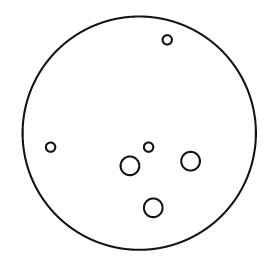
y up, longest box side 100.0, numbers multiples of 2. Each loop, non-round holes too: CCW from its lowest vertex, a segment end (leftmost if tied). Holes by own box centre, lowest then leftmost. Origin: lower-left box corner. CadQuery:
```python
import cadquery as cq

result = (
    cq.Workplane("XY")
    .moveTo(50.0, 50.0)
    .circle(50.0)
    .moveTo(56.0, 18.0)
    .circle(4.0)
    .moveTo(46.0, 36.0)
    .circle(4.0)
    .moveTo(72.0, 38.0)
    .circle(4.0)
    .moveTo(12.0, 44.0)
    .circle(2.0)
    .moveTo(54.0, 44.0)
    .circle(2.0)
    .moveTo(62.0, 90.0)
    .circle(2.0)
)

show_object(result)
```